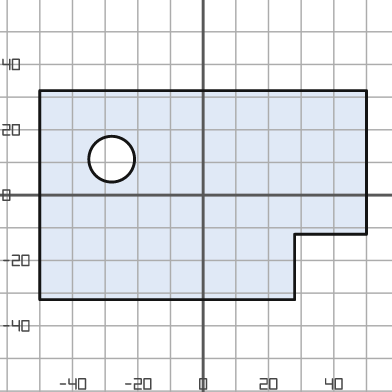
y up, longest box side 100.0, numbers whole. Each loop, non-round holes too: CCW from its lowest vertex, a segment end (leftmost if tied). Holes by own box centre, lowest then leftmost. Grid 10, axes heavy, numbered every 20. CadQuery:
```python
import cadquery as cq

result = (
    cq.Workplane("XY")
    .moveTo(-50.0, -32.0)
    .lineTo(28.0, -32.0)
    .lineTo(28.0, -12.0)
    .lineTo(50.0, -12.0)
    .lineTo(50.0, 32.0)
    .lineTo(-50.0, 32.0)
    .close()
    .moveTo(-28.0, 11.0)
    .circle(7.0)
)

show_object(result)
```